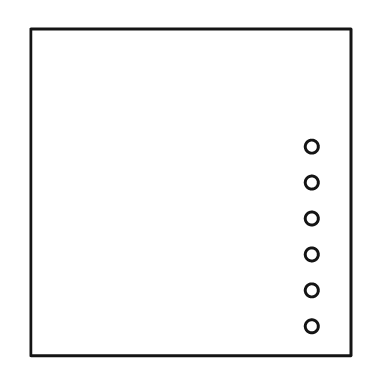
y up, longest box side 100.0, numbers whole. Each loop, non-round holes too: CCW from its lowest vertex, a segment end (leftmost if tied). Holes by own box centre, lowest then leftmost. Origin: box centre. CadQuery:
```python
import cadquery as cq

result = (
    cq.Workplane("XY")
    .moveTo(-49.0, -50.0)
    .lineTo(49.0, -50.0)
    .lineTo(49.0, 50.0)
    .lineTo(-49.0, 50.0)
    .close()
    .moveTo(37.0, -41.0)
    .circle(2.0)
    .moveTo(37.0, -30.0)
    .circle(2.0)
    .moveTo(37.0, -19.0)
    .circle(2.0)
    .moveTo(37.0, -8.0)
    .circle(2.0)
    .moveTo(37.0, 3.0)
    .circle(2.0)
    .moveTo(37.0, 14.0)
    .circle(2.0)
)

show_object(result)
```